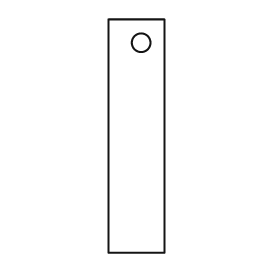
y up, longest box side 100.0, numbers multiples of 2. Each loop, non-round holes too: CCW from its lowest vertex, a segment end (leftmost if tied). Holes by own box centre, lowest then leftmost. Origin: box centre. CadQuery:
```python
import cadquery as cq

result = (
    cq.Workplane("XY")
    .moveTo(-12.0, -50.0)
    .lineTo(12.0, -50.0)
    .lineTo(12.0, 50.0)
    .lineTo(-12.0, 50.0)
    .close()
    .moveTo(2.0, 40.0)
    .circle(4.0)
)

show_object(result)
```